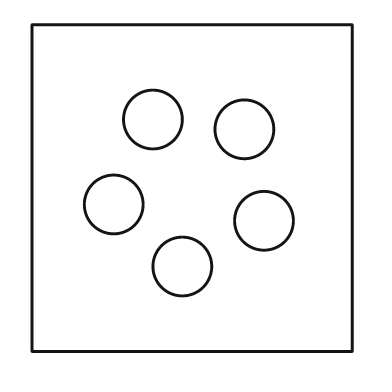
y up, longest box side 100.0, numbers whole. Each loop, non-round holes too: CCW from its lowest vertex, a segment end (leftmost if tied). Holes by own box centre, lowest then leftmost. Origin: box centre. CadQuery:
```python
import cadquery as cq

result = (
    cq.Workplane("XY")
    .moveTo(-49.0, -50.0)
    .lineTo(49.0, -50.0)
    .lineTo(49.0, 50.0)
    .lineTo(-49.0, 50.0)
    .close()
    .moveTo(-3.0, -24.0)
    .circle(9.0)
    .moveTo(22.0, -10.0)
    .circle(9.0)
    .moveTo(-24.0, -5.0)
    .circle(9.0)
    .moveTo(16.0, 18.0)
    .circle(9.0)
    .moveTo(-12.0, 21.0)
    .circle(9.0)
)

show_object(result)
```